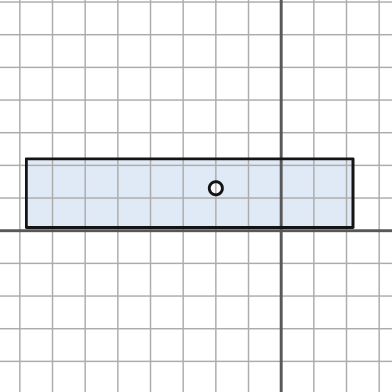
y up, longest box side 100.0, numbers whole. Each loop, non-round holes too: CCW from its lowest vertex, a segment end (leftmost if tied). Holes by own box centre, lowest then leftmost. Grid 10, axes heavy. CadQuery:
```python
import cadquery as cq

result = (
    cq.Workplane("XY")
    .moveTo(-78.0, 1.0)
    .lineTo(22.0, 1.0)
    .lineTo(22.0, 22.0)
    .lineTo(-78.0, 22.0)
    .close()
    .moveTo(-20.0, 13.0)
    .circle(2.0)
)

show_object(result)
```